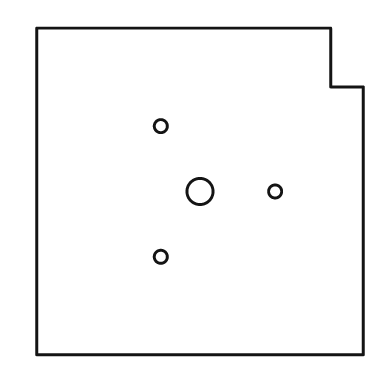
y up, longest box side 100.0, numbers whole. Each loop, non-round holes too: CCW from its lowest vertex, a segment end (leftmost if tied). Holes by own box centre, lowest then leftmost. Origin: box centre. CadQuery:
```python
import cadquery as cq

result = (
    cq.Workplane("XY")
    .moveTo(-50.0, -50.0)
    .lineTo(50.0, -50.0)
    .lineTo(50.0, 32.0)
    .lineTo(40.0, 32.0)
    .lineTo(40.0, 50.0)
    .lineTo(-50.0, 50.0)
    .close()
    .moveTo(-12.0, -20.0)
    .circle(2.0)
    .moveTo(0.0, 0.0)
    .circle(4.0)
    .moveTo(23.0, 0.0)
    .circle(2.0)
    .moveTo(-12.0, 20.0)
    .circle(2.0)
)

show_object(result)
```